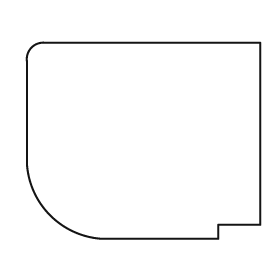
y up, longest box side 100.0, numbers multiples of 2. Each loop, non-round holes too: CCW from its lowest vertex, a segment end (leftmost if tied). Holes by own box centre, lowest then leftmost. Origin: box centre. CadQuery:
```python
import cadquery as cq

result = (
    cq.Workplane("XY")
    .moveTo(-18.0, -42.0)
    .lineTo(32.0, -42.0)
    .lineTo(32.0, -36.0)
    .lineTo(50.0, -36.0)
    .lineTo(50.0, 42.0)
    .lineTo(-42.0, 42.0)
    .threePointArc((-48.0, 40.0), (-50.0, 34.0))
    .lineTo(-50.0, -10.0)
    .threePointArc((-40.0, -32.0), (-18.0, -42.0))
    .close()
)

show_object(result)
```